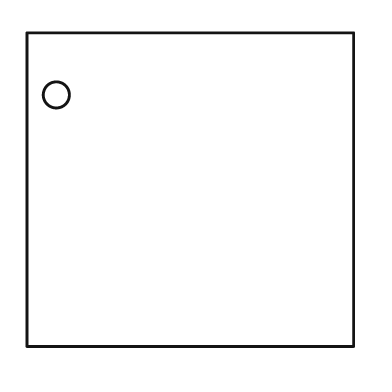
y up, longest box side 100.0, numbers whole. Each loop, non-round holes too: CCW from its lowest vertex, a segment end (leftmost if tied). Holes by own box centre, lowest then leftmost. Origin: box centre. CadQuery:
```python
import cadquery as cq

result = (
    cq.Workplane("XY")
    .moveTo(-50.0, -48.0)
    .lineTo(50.0, -48.0)
    .lineTo(50.0, 48.0)
    .lineTo(-50.0, 48.0)
    .close()
    .moveTo(-41.0, 29.0)
    .circle(4.0)
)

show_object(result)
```